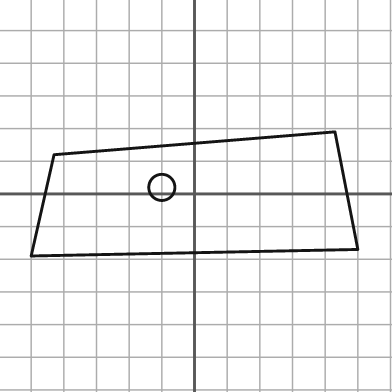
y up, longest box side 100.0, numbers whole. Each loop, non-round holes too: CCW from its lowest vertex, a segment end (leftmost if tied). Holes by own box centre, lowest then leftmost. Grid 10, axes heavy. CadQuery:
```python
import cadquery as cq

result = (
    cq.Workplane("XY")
    .moveTo(-50.0, -19.0)
    .lineTo(50.0, -17.0)
    .lineTo(43.0, 19.0)
    .lineTo(-43.0, 12.0)
    .close()
    .moveTo(-10.0, 2.0)
    .circle(4.0)
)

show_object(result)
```